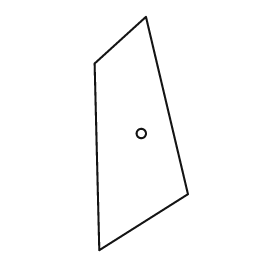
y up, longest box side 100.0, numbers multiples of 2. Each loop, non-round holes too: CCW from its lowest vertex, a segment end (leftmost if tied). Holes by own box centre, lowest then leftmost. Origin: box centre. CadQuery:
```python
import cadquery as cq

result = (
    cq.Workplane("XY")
    .moveTo(-18.0, -50.0)
    .lineTo(20.0, -26.0)
    .lineTo(2.0, 50.0)
    .lineTo(-20.0, 30.0)
    .close()
    .moveTo(0.0, 0.0)
    .circle(2.0)
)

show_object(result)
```